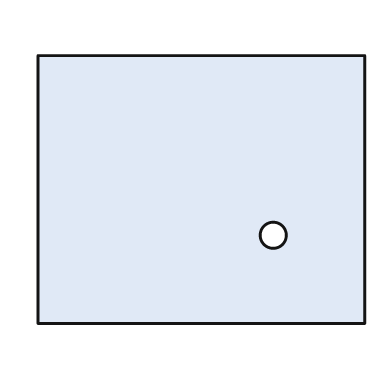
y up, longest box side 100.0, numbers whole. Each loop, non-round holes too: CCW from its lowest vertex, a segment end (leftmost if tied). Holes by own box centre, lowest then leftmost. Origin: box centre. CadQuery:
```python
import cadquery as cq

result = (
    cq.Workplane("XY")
    .moveTo(-50.0, -41.0)
    .lineTo(50.0, -41.0)
    .lineTo(50.0, 41.0)
    .lineTo(-50.0, 41.0)
    .close()
    .moveTo(22.0, -14.0)
    .circle(4.0)
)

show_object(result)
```